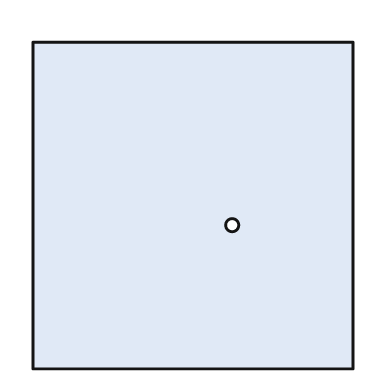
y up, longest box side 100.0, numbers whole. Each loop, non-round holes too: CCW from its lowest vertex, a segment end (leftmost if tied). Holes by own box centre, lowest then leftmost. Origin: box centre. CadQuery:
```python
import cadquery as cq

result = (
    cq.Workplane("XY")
    .moveTo(-49.0, -50.0)
    .lineTo(49.0, -50.0)
    .lineTo(49.0, 50.0)
    .lineTo(-49.0, 50.0)
    .close()
    .moveTo(12.0, -6.0)
    .circle(2.0)
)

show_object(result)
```